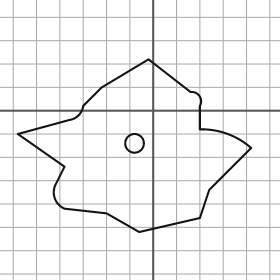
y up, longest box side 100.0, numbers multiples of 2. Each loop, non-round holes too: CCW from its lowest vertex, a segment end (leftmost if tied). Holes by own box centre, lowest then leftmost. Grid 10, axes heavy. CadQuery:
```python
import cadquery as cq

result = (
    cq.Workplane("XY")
    .moveTo(-6.0, -52.0)
    .lineTo(20.0, -46.0)
    .lineTo(24.0, -34.0)
    .lineTo(42.0, -16.0)
    .threePointArc((32.0, -10.0), (20.0, -8.0))
    .lineTo(20.0, 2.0)
    .threePointArc((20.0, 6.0), (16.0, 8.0))
    .lineTo(-2.0, 22.0)
    .lineTo(-22.0, 10.0)
    .lineTo(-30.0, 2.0)
    .threePointArc((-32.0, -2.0), (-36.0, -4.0))
    .lineTo(-58.0, -10.0)
    .lineTo(-38.0, -24.0)
    .lineTo(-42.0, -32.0)
    .threePointArc((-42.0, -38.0), (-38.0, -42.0))
    .lineTo(-20.0, -44.0)
    .close()
    .moveTo(-8.0, -14.0)
    .circle(4.0)
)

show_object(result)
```